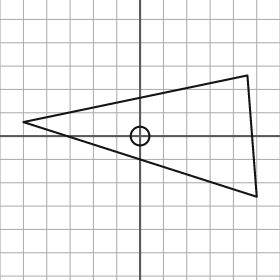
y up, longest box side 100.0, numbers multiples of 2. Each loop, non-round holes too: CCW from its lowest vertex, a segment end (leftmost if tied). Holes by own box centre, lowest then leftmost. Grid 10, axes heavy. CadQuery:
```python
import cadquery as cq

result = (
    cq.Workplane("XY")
    .moveTo(50.0, -26.0)
    .lineTo(46.0, 26.0)
    .lineTo(-50.0, 6.0)
    .close()
    .moveTo(0.0, 0.0)
    .circle(4.0)
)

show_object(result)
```